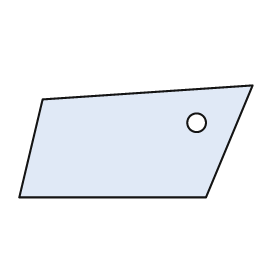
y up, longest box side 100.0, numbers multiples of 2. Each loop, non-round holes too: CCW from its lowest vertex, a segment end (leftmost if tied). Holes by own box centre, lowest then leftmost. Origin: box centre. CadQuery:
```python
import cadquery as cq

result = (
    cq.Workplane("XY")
    .moveTo(-50.0, -24.0)
    .lineTo(30.0, -24.0)
    .lineTo(50.0, 24.0)
    .lineTo(-40.0, 18.0)
    .close()
    .moveTo(26.0, 8.0)
    .circle(4.0)
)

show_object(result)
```